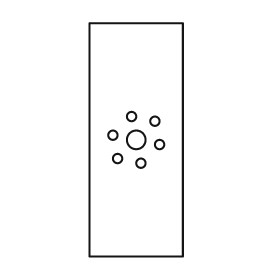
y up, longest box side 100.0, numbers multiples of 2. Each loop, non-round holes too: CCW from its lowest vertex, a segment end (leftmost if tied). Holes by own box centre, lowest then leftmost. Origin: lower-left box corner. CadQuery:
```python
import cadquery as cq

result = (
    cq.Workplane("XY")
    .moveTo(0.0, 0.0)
    .lineTo(40.0, 0.0)
    .lineTo(40.0, 100.0)
    .lineTo(0.0, 100.0)
    .close()
    .moveTo(22.0, 40.0)
    .circle(2.0)
    .moveTo(12.0, 42.0)
    .circle(2.0)
    .moveTo(30.0, 48.0)
    .circle(2.0)
    .moveTo(20.0, 50.0)
    .circle(4.0)
    .moveTo(10.0, 52.0)
    .circle(2.0)
    .moveTo(28.0, 58.0)
    .circle(2.0)
    .moveTo(18.0, 60.0)
    .circle(2.0)
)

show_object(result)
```